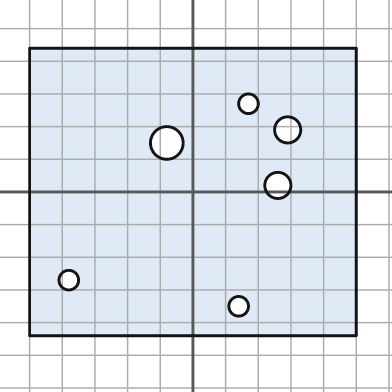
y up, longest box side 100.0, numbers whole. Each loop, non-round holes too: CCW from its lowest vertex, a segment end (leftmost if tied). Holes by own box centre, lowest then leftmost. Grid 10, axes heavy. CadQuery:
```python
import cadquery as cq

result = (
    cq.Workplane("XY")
    .moveTo(-50.0, -44.0)
    .lineTo(50.0, -44.0)
    .lineTo(50.0, 44.0)
    .lineTo(-50.0, 44.0)
    .close()
    .moveTo(14.0, -35.0)
    .circle(3.0)
    .moveTo(-38.0, -27.0)
    .circle(3.0)
    .moveTo(26.0, 2.0)
    .circle(4.0)
    .moveTo(-8.0, 15.0)
    .circle(5.0)
    .moveTo(29.0, 19.0)
    .circle(4.0)
    .moveTo(17.0, 27.0)
    .circle(3.0)
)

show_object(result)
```